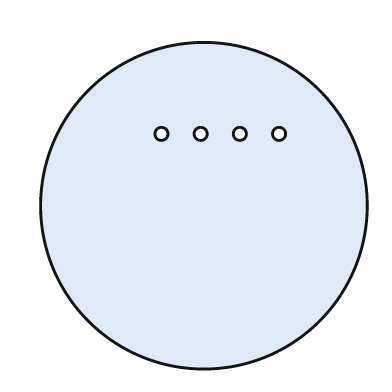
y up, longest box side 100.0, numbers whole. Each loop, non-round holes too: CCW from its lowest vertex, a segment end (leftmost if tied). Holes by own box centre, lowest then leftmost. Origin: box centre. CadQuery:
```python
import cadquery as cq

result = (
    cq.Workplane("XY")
    .moveTo(0.0, 0.0)
    .circle(50.0)
    .moveTo(-13.0, 22.0)
    .circle(2.0)
    .moveTo(-1.0, 22.0)
    .circle(2.0)
    .moveTo(11.0, 22.0)
    .circle(2.0)
    .moveTo(23.0, 22.0)
    .circle(2.0)
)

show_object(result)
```